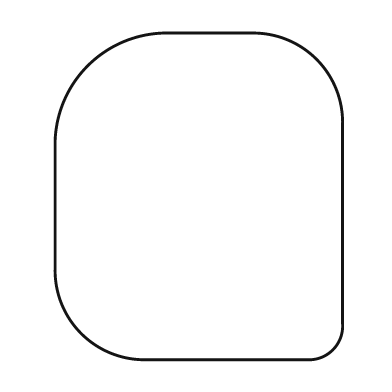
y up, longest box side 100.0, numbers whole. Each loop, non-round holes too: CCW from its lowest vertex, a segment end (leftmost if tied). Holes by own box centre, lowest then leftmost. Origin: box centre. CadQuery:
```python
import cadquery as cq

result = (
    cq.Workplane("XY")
    .moveTo(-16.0, -50.0)
    .lineTo(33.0, -50.0)
    .threePointArc((41.0, -47.0), (44.0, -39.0))
    .lineTo(44.0, 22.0)
    .threePointArc((36.0, 42.0), (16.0, 50.0))
    .lineTo(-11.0, 50.0)
    .threePointArc((-34.0, 40.0), (-44.0, 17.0))
    .lineTo(-44.0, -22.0)
    .threePointArc((-36.0, -42.0), (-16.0, -50.0))
    .close()
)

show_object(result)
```